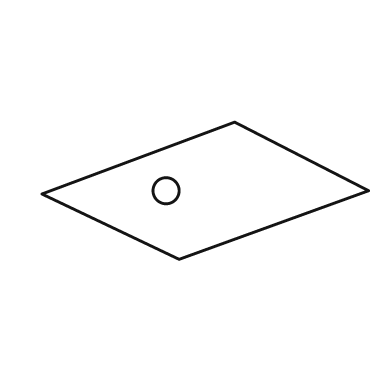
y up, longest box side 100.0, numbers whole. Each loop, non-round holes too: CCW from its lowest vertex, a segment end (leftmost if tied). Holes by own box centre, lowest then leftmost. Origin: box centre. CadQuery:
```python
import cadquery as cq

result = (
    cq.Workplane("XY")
    .moveTo(-8.0, -21.0)
    .lineTo(50.0, 0.0)
    .lineTo(9.0, 21.0)
    .lineTo(-50.0, -1.0)
    .close()
    .moveTo(-12.0, 0.0)
    .circle(4.0)
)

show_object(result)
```